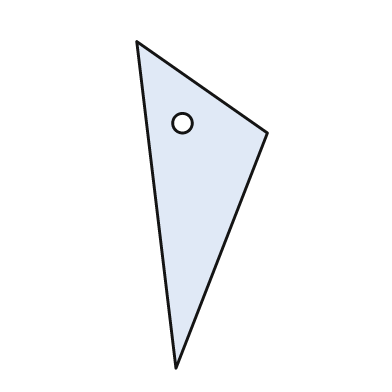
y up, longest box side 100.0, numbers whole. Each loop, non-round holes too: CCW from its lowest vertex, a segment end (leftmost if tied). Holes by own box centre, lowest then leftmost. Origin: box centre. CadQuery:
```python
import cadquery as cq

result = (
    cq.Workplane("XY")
    .moveTo(-8.0, -50.0)
    .lineTo(20.0, 22.0)
    .lineTo(-20.0, 50.0)
    .close()
    .moveTo(-6.0, 25.0)
    .circle(3.0)
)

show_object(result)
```